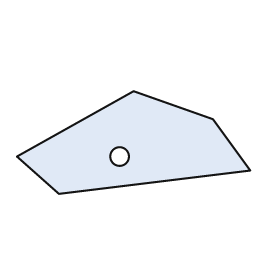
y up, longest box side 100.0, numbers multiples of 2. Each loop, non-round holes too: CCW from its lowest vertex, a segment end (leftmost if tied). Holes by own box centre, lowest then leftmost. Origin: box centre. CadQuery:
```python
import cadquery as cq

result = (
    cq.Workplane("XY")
    .moveTo(-32.0, -22.0)
    .lineTo(50.0, -12.0)
    .lineTo(34.0, 10.0)
    .lineTo(0.0, 22.0)
    .lineTo(-50.0, -6.0)
    .close()
    .moveTo(-6.0, -6.0)
    .circle(4.0)
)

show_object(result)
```